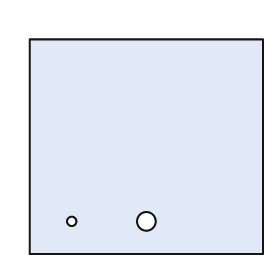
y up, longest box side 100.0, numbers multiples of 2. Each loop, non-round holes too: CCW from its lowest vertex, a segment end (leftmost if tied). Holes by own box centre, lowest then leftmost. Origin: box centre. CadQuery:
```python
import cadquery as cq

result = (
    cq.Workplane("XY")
    .moveTo(-50.0, -46.0)
    .lineTo(50.0, -46.0)
    .lineTo(50.0, 46.0)
    .lineTo(-50.0, 46.0)
    .close()
    .moveTo(-32.0, -32.0)
    .circle(2.0)
    .moveTo(0.0, -32.0)
    .circle(4.0)
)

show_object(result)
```